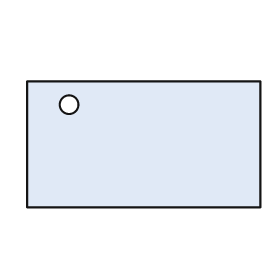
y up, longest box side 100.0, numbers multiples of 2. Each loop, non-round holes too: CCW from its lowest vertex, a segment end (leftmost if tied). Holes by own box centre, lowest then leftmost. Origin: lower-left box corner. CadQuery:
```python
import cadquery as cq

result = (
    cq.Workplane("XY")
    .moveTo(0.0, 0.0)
    .lineTo(100.0, 0.0)
    .lineTo(100.0, 54.0)
    .lineTo(0.0, 54.0)
    .close()
    .moveTo(18.0, 44.0)
    .circle(4.0)
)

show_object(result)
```